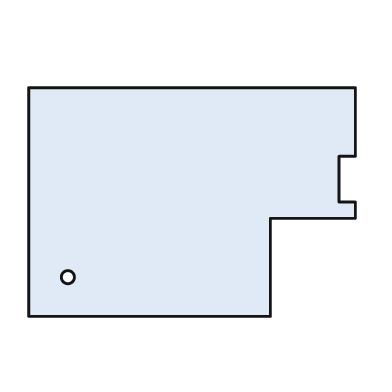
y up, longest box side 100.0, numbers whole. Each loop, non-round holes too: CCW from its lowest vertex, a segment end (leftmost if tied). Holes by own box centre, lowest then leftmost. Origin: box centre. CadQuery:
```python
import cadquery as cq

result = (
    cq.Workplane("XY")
    .moveTo(-50.0, -35.0)
    .lineTo(24.0, -35.0)
    .lineTo(24.0, -5.0)
    .lineTo(50.0, -5.0)
    .lineTo(50.0, 0.0)
    .lineTo(45.0, 0.0)
    .lineTo(45.0, 14.0)
    .lineTo(50.0, 14.0)
    .lineTo(50.0, 35.0)
    .lineTo(-50.0, 35.0)
    .close()
    .moveTo(-38.0, -23.0)
    .circle(2.0)
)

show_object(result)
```